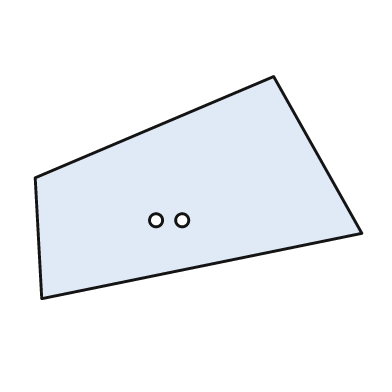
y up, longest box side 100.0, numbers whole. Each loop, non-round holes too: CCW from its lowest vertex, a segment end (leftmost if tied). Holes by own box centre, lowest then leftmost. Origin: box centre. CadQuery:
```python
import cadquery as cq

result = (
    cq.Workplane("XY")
    .moveTo(-48.0, -34.0)
    .lineTo(50.0, -14.0)
    .lineTo(23.0, 34.0)
    .lineTo(-50.0, 3.0)
    .close()
    .moveTo(-13.0, -10.0)
    .circle(2.0)
    .moveTo(-5.0, -10.0)
    .circle(2.0)
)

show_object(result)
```